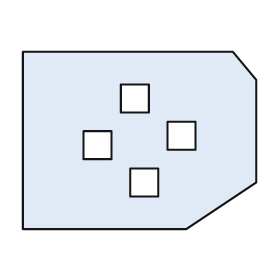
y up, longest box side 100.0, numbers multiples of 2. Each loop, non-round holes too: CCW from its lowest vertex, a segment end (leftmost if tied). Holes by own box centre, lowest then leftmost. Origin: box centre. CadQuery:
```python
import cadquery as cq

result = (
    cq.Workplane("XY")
    .moveTo(-50.0, -38.0)
    .lineTo(20.0, -38.0)
    .lineTo(50.0, -18.0)
    .lineTo(50.0, 26.0)
    .lineTo(40.0, 38.0)
    .lineTo(-50.0, 38.0)
    .close()
    .moveTo(-4.0, -24.0)
    .lineTo(8.0, -24.0)
    .lineTo(8.0, -12.0)
    .lineTo(-4.0, -12.0)
    .close()
    .moveTo(-24.0, -8.0)
    .lineTo(-12.0, -8.0)
    .lineTo(-12.0, 4.0)
    .lineTo(-24.0, 4.0)
    .close()
    .moveTo(12.0, -4.0)
    .lineTo(24.0, -4.0)
    .lineTo(24.0, 8.0)
    .lineTo(12.0, 8.0)
    .close()
    .moveTo(-8.0, 12.0)
    .lineTo(4.0, 12.0)
    .lineTo(4.0, 24.0)
    .lineTo(-8.0, 24.0)
    .close()
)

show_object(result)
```